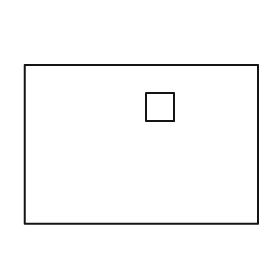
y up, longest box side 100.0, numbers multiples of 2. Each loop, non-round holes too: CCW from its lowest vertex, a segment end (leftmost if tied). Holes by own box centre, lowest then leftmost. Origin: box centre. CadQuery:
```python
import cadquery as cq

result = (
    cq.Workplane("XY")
    .moveTo(-50.0, -34.0)
    .lineTo(50.0, -34.0)
    .lineTo(50.0, 34.0)
    .lineTo(-50.0, 34.0)
    .close()
    .moveTo(2.0, 10.0)
    .lineTo(14.0, 10.0)
    .lineTo(14.0, 22.0)
    .lineTo(2.0, 22.0)
    .close()
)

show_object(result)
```